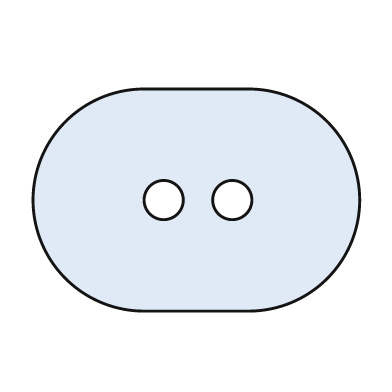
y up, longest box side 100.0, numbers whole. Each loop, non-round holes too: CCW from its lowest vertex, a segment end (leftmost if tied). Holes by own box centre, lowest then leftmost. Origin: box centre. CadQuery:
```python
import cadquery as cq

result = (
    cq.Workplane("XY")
    .moveTo(-16.0, -34.0)
    .lineTo(16.0, -34.0)
    .threePointArc((50.0, 0.0), (16.0, 34.0))
    .lineTo(-16.0, 34.0)
    .threePointArc((-50.0, 0.0), (-16.0, -34.0))
    .close()
    .moveTo(-10.0, 0.0)
    .circle(6.0)
    .moveTo(11.0, 0.0)
    .circle(6.0)
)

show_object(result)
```